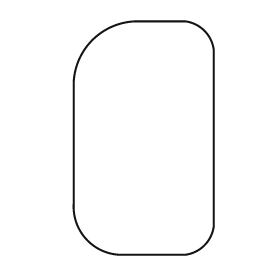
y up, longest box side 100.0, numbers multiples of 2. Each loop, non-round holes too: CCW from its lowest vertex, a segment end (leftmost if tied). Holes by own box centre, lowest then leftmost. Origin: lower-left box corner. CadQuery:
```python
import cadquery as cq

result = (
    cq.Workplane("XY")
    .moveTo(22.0, 0.0)
    .lineTo(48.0, 0.0)
    .threePointArc((56.0, 4.0), (60.0, 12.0))
    .lineTo(60.0, 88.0)
    .threePointArc((56.0, 96.0), (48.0, 100.0))
    .lineTo(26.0, 100.0)
    .threePointArc((8.0, 92.0), (0.0, 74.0))
    .lineTo(0.0, 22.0)
    .threePointArc((6.0, 6.0), (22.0, 0.0))
    .close()
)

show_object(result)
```